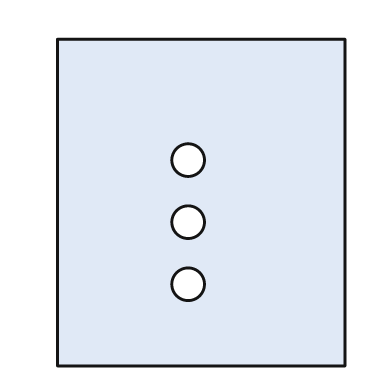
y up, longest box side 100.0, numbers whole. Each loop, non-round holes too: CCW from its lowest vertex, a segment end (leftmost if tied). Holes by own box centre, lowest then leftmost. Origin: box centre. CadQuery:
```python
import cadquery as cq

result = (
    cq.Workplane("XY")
    .moveTo(-44.0, -50.0)
    .lineTo(44.0, -50.0)
    .lineTo(44.0, 50.0)
    .lineTo(-44.0, 50.0)
    .close()
    .moveTo(-4.0, -25.0)
    .circle(5.0)
    .moveTo(-4.0, -6.0)
    .circle(5.0)
    .moveTo(-4.0, 13.0)
    .circle(5.0)
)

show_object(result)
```